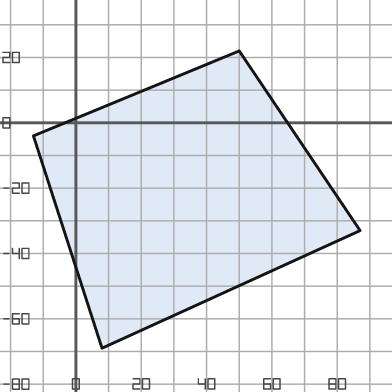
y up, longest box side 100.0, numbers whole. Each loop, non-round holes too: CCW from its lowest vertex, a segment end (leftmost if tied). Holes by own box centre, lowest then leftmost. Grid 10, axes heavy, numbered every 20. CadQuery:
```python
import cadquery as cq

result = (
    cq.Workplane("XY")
    .moveTo(8.0, -69.0)
    .lineTo(87.0, -33.0)
    .lineTo(50.0, 22.0)
    .lineTo(-13.0, -4.0)
    .close()
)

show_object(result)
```